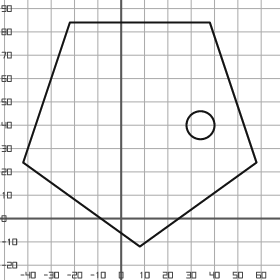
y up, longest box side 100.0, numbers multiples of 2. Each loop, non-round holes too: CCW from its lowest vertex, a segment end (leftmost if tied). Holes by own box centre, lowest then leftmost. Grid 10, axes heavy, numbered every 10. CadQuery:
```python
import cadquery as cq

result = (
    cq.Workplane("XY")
    .moveTo(8.0, -12.0)
    .lineTo(58.0, 24.0)
    .lineTo(38.0, 84.0)
    .lineTo(-22.0, 84.0)
    .lineTo(-42.0, 24.0)
    .close()
    .moveTo(34.0, 40.0)
    .circle(6.0)
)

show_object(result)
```